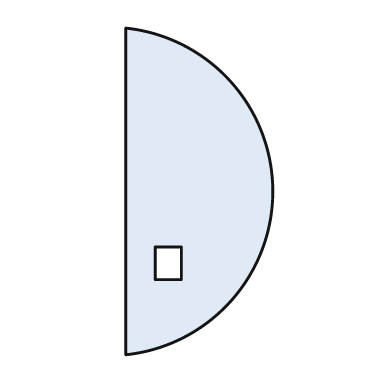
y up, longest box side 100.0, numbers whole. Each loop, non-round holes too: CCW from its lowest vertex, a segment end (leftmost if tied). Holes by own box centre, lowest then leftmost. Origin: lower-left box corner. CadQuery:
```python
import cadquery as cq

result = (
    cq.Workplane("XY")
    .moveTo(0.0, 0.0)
    .threePointArc((45.0, 50.0), (0.0, 100.0))
    .close()
    .moveTo(9.0, 23.0)
    .lineTo(17.0, 23.0)
    .lineTo(17.0, 33.0)
    .lineTo(9.0, 33.0)
    .close()
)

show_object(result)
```